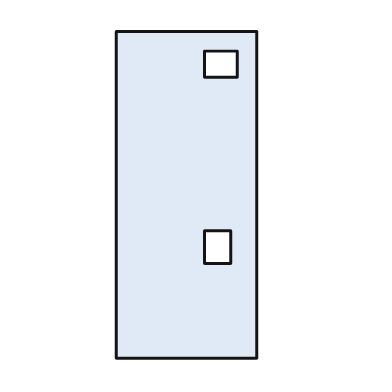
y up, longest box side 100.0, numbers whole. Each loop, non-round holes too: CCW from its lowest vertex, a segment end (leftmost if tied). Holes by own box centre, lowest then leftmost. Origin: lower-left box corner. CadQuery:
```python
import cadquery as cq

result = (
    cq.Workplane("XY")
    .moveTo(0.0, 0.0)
    .lineTo(43.0, 0.0)
    .lineTo(43.0, 100.0)
    .lineTo(0.0, 100.0)
    .close()
    .moveTo(27.0, 29.0)
    .lineTo(35.0, 29.0)
    .lineTo(35.0, 39.0)
    .lineTo(27.0, 39.0)
    .close()
    .moveTo(27.0, 86.0)
    .lineTo(37.0, 86.0)
    .lineTo(37.0, 94.0)
    .lineTo(27.0, 94.0)
    .close()
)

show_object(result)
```